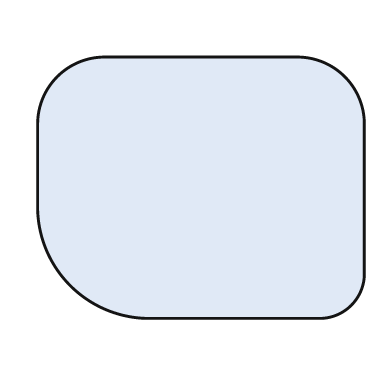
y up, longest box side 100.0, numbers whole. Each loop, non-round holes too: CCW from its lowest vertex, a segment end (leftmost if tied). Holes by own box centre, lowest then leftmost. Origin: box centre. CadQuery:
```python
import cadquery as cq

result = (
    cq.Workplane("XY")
    .moveTo(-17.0, -40.0)
    .lineTo(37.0, -40.0)
    .threePointArc((46.0, -36.0), (50.0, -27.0))
    .lineTo(50.0, 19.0)
    .threePointArc((44.0, 34.0), (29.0, 40.0))
    .lineTo(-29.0, 40.0)
    .threePointArc((-44.0, 34.0), (-50.0, 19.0))
    .lineTo(-50.0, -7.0)
    .threePointArc((-40.0, -30.0), (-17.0, -40.0))
    .close()
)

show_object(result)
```